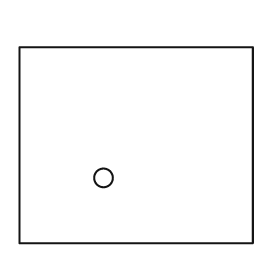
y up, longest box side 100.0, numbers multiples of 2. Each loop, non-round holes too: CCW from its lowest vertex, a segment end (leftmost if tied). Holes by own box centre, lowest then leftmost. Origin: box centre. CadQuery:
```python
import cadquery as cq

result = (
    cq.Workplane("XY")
    .moveTo(-50.0, -42.0)
    .lineTo(50.0, -42.0)
    .lineTo(50.0, 42.0)
    .lineTo(-50.0, 42.0)
    .close()
    .moveTo(-14.0, -14.0)
    .circle(4.0)
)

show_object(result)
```